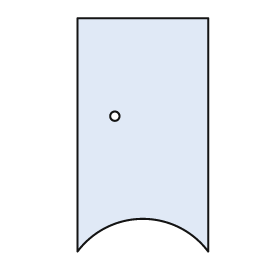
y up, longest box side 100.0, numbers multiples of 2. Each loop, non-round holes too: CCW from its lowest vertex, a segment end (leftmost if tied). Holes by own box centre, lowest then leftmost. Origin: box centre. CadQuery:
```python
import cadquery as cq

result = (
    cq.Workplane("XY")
    .moveTo(-28.0, -50.0)
    .threePointArc((0.0, -36.0), (28.0, -50.0))
    .lineTo(28.0, 50.0)
    .lineTo(-28.0, 50.0)
    .close()
    .moveTo(-12.0, 8.0)
    .circle(2.0)
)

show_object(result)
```